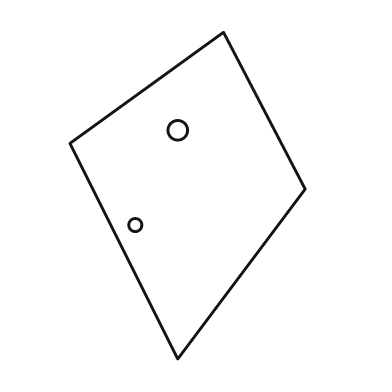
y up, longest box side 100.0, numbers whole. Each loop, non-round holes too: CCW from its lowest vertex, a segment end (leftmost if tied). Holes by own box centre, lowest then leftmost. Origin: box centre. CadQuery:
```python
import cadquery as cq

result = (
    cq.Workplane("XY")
    .moveTo(-3.0, -50.0)
    .lineTo(36.0, 2.0)
    .lineTo(11.0, 50.0)
    .lineTo(-36.0, 16.0)
    .close()
    .moveTo(-16.0, -9.0)
    .circle(2.0)
    .moveTo(-3.0, 20.0)
    .circle(3.0)
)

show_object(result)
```